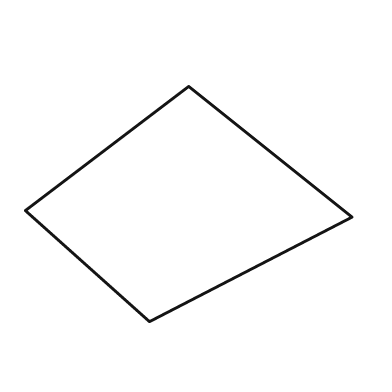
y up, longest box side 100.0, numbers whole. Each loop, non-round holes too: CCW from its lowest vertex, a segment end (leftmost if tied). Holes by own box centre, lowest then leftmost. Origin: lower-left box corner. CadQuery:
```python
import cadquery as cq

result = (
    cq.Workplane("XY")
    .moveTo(38.0, 0.0)
    .lineTo(100.0, 32.0)
    .lineTo(50.0, 72.0)
    .lineTo(0.0, 34.0)
    .close()
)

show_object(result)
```